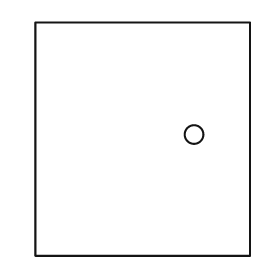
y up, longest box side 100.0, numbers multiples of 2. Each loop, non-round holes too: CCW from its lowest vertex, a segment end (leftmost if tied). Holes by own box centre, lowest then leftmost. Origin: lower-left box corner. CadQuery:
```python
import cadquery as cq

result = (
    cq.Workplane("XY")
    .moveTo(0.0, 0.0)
    .lineTo(92.0, 0.0)
    .lineTo(92.0, 100.0)
    .lineTo(0.0, 100.0)
    .close()
    .moveTo(68.0, 52.0)
    .circle(4.0)
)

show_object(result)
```